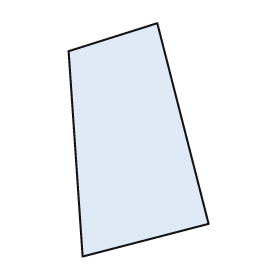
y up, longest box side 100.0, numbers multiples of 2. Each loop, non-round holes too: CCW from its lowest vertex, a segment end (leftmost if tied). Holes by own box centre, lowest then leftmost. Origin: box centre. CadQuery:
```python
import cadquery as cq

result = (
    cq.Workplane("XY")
    .moveTo(-24.0, -50.0)
    .lineTo(30.0, -36.0)
    .lineTo(8.0, 50.0)
    .lineTo(-30.0, 38.0)
    .close()
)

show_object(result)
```